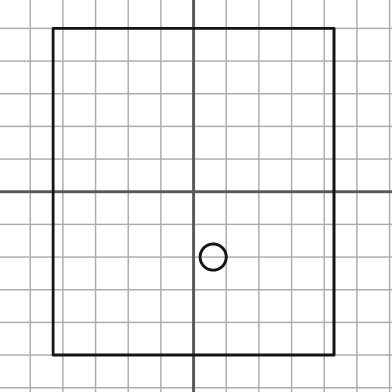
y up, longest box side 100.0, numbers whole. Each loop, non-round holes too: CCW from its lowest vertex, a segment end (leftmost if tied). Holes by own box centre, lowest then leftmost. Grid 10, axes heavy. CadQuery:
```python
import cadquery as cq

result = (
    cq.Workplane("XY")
    .moveTo(-43.0, -50.0)
    .lineTo(43.0, -50.0)
    .lineTo(43.0, 50.0)
    .lineTo(-43.0, 50.0)
    .close()
    .moveTo(6.0, -20.0)
    .circle(4.0)
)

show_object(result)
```